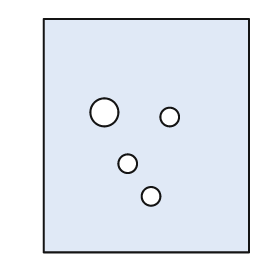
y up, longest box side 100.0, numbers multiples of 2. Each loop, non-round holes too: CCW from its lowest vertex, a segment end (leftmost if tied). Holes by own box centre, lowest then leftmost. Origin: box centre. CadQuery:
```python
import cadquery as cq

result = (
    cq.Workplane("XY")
    .moveTo(-44.0, -50.0)
    .lineTo(44.0, -50.0)
    .lineTo(44.0, 50.0)
    .lineTo(-44.0, 50.0)
    .close()
    .moveTo(2.0, -26.0)
    .circle(4.0)
    .moveTo(-8.0, -12.0)
    .circle(4.0)
    .moveTo(10.0, 8.0)
    .circle(4.0)
    .moveTo(-18.0, 10.0)
    .circle(6.0)
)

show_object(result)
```